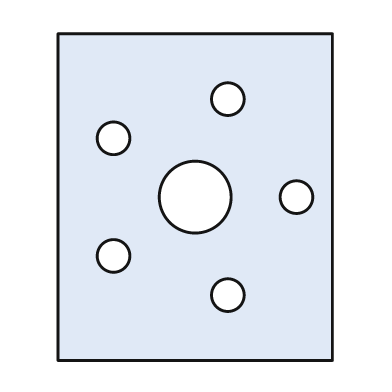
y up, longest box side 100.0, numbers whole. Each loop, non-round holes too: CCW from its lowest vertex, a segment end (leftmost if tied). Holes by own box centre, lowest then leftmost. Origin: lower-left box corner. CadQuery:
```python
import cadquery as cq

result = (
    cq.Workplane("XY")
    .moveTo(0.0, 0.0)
    .lineTo(84.0, 0.0)
    .lineTo(84.0, 100.0)
    .lineTo(0.0, 100.0)
    .close()
    .moveTo(52.0, 20.0)
    .circle(5.0)
    .moveTo(17.0, 32.0)
    .circle(5.0)
    .moveTo(42.0, 50.0)
    .circle(11.0)
    .moveTo(73.0, 50.0)
    .circle(5.0)
    .moveTo(17.0, 68.0)
    .circle(5.0)
    .moveTo(52.0, 80.0)
    .circle(5.0)
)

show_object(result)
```